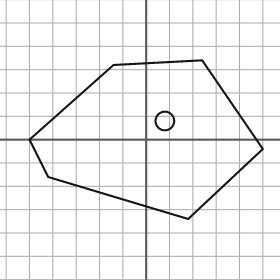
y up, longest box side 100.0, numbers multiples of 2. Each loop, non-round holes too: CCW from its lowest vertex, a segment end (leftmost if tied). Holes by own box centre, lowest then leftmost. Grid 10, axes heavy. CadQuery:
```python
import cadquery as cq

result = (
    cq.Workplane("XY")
    .moveTo(18.0, -34.0)
    .lineTo(50.0, -4.0)
    .lineTo(24.0, 34.0)
    .lineTo(-14.0, 32.0)
    .lineTo(-50.0, 0.0)
    .lineTo(-42.0, -16.0)
    .close()
    .moveTo(8.0, 8.0)
    .circle(4.0)
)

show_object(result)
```